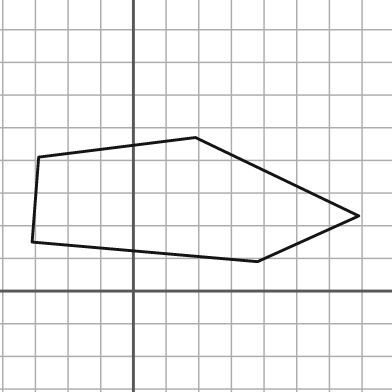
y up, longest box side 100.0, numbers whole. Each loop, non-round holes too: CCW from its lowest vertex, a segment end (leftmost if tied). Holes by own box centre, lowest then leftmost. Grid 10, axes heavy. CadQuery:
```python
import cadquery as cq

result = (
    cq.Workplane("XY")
    .moveTo(38.0, 9.0)
    .lineTo(69.0, 23.0)
    .lineTo(19.0, 47.0)
    .lineTo(-29.0, 41.0)
    .lineTo(-31.0, 15.0)
    .close()
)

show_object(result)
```